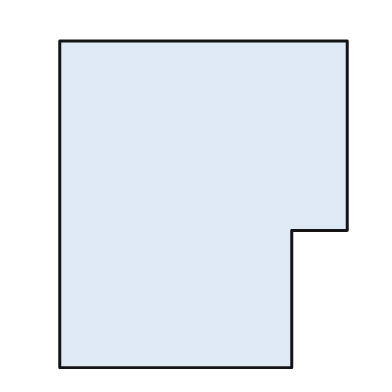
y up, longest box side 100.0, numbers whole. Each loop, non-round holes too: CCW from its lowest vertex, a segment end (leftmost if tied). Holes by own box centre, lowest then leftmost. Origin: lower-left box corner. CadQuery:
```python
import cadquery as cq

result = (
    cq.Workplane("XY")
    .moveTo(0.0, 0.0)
    .lineTo(71.0, 0.0)
    .lineTo(71.0, 42.0)
    .lineTo(88.0, 42.0)
    .lineTo(88.0, 100.0)
    .lineTo(0.0, 100.0)
    .close()
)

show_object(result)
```